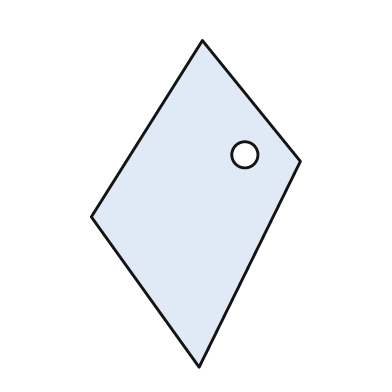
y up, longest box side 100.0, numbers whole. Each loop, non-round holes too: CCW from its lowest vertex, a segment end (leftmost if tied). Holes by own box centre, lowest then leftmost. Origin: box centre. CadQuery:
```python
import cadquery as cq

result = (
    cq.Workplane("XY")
    .moveTo(1.0, -50.0)
    .lineTo(32.0, 13.0)
    .lineTo(2.0, 50.0)
    .lineTo(-32.0, -4.0)
    .close()
    .moveTo(15.0, 15.0)
    .circle(4.0)
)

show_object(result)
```